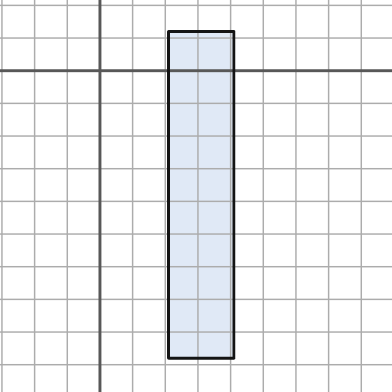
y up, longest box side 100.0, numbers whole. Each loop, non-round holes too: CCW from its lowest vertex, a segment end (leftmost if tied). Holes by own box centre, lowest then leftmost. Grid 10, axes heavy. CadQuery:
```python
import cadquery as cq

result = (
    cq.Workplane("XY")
    .moveTo(21.0, -88.0)
    .lineTo(41.0, -88.0)
    .lineTo(41.0, 12.0)
    .lineTo(21.0, 12.0)
    .close()
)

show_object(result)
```